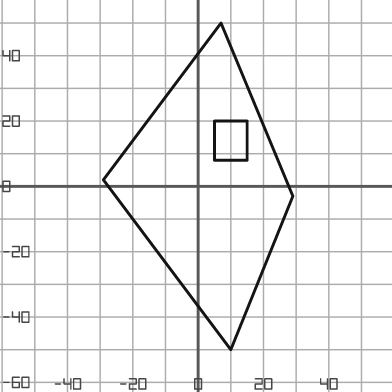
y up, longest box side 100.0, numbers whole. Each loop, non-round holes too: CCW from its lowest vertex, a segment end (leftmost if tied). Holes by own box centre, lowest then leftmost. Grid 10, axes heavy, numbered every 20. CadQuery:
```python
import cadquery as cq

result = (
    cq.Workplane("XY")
    .moveTo(10.0, -50.0)
    .lineTo(29.0, -3.0)
    .lineTo(7.0, 50.0)
    .lineTo(-29.0, 2.0)
    .close()
    .moveTo(5.0, 8.0)
    .lineTo(15.0, 8.0)
    .lineTo(15.0, 20.0)
    .lineTo(5.0, 20.0)
    .close()
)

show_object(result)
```